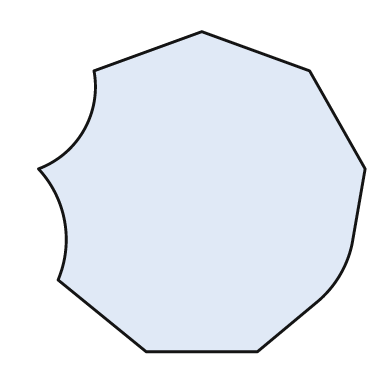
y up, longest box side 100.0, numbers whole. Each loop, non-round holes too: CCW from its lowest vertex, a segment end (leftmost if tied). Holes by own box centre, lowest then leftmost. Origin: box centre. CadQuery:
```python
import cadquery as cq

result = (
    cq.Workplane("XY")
    .moveTo(-17.0, -49.0)
    .lineTo(17.0, -49.0)
    .lineTo(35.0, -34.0)
    .threePointArc((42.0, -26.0), (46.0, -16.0))
    .lineTo(50.0, 7.0)
    .lineTo(33.0, 37.0)
    .lineTo(0.0, 49.0)
    .lineTo(-33.0, 37.0)
    .threePointArc((-36.0, 19.0), (-50.0, 7.0))
    .threePointArc((-42.0, -9.0), (-44.0, -27.0))
    .close()
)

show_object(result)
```